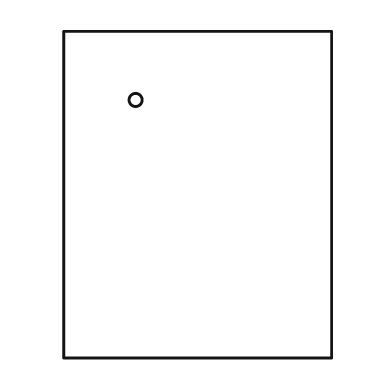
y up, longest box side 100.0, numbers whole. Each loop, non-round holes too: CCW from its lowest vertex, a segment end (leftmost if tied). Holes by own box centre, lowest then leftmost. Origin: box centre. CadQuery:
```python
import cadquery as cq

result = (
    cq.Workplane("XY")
    .moveTo(-41.0, -50.0)
    .lineTo(41.0, -50.0)
    .lineTo(41.0, 50.0)
    .lineTo(-41.0, 50.0)
    .close()
    .moveTo(-19.0, 29.0)
    .circle(2.0)
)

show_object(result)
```